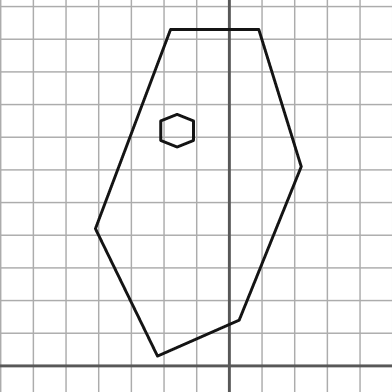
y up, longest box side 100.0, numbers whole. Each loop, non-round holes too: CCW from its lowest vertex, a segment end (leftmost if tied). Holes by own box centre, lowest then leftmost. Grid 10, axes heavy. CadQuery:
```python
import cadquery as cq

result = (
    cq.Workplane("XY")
    .moveTo(-22.0, 3.0)
    .lineTo(3.0, 14.0)
    .lineTo(22.0, 61.0)
    .lineTo(9.0, 103.0)
    .lineTo(-18.0, 103.0)
    .lineTo(-41.0, 42.0)
    .close()
    .moveTo(-16.0, 67.0)
    .lineTo(-11.0, 69.0)
    .lineTo(-11.0, 75.0)
    .lineTo(-16.0, 77.0)
    .lineTo(-21.0, 75.0)
    .lineTo(-21.0, 69.0)
    .close()
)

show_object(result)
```